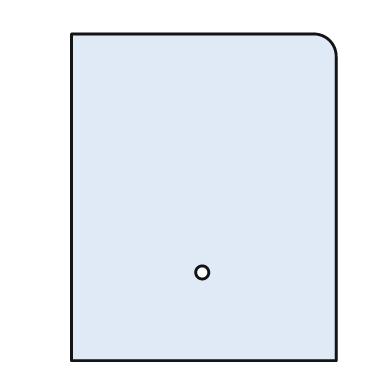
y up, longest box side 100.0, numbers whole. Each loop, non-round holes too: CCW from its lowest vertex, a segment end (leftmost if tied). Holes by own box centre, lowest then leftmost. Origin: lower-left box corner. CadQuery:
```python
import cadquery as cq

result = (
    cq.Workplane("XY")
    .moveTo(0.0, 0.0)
    .lineTo(81.0, 0.0)
    .lineTo(81.0, 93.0)
    .threePointArc((79.0, 98.0), (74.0, 100.0))
    .lineTo(0.0, 100.0)
    .close()
    .moveTo(40.0, 27.0)
    .circle(2.0)
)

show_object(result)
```